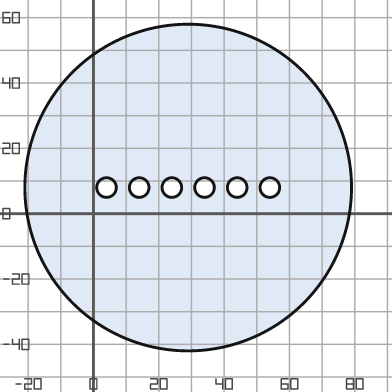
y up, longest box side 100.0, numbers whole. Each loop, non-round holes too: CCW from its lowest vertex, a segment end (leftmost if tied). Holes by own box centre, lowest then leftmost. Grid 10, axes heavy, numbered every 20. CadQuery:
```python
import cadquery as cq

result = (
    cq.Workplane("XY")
    .moveTo(29.0, 8.0)
    .circle(50.0)
    .moveTo(4.0, 8.0)
    .circle(3.0)
    .moveTo(14.0, 8.0)
    .circle(3.0)
    .moveTo(24.0, 8.0)
    .circle(3.0)
    .moveTo(34.0, 8.0)
    .circle(3.0)
    .moveTo(44.0, 8.0)
    .circle(3.0)
    .moveTo(54.0, 8.0)
    .circle(3.0)
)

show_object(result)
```